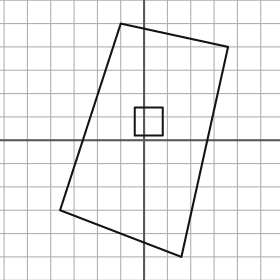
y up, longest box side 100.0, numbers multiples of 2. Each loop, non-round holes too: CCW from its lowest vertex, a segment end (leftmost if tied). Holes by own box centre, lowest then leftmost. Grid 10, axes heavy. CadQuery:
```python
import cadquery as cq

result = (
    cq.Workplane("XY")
    .moveTo(16.0, -50.0)
    .lineTo(36.0, 40.0)
    .lineTo(-10.0, 50.0)
    .lineTo(-36.0, -30.0)
    .close()
    .moveTo(-4.0, 2.0)
    .lineTo(8.0, 2.0)
    .lineTo(8.0, 14.0)
    .lineTo(-4.0, 14.0)
    .close()
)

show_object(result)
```